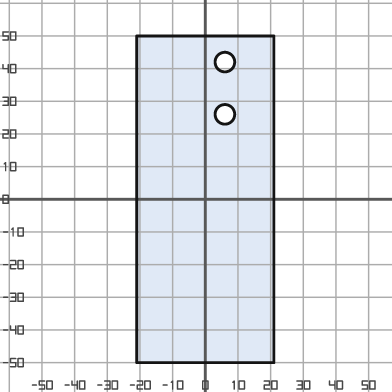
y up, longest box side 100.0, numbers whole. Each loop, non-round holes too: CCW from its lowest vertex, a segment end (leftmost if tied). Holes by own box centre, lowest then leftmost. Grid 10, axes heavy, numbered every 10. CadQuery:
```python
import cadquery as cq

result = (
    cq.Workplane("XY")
    .moveTo(-21.0, -50.0)
    .lineTo(21.0, -50.0)
    .lineTo(21.0, 50.0)
    .lineTo(-21.0, 50.0)
    .close()
    .moveTo(6.0, 26.0)
    .circle(3.0)
    .moveTo(6.0, 42.0)
    .circle(3.0)
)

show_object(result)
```